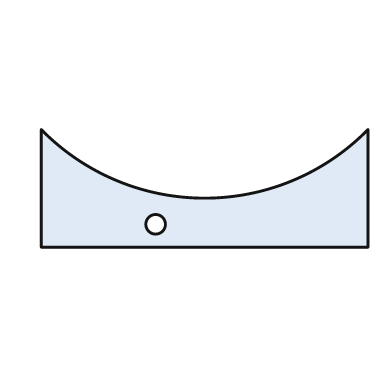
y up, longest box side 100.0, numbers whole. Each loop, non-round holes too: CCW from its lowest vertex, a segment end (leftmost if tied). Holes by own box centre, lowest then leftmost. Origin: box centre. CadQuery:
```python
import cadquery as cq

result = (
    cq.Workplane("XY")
    .moveTo(-50.0, -18.0)
    .lineTo(50.0, -18.0)
    .lineTo(50.0, 18.0)
    .threePointArc((0.0, -3.0), (-50.0, 18.0))
    .close()
    .moveTo(-15.0, -11.0)
    .circle(3.0)
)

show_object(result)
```